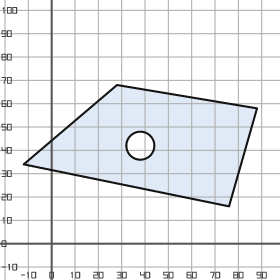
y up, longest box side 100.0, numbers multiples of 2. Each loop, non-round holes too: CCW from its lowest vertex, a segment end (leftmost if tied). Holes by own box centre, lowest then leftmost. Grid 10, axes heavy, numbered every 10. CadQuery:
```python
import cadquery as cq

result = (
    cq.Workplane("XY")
    .moveTo(76.0, 16.0)
    .lineTo(88.0, 58.0)
    .lineTo(28.0, 68.0)
    .lineTo(-12.0, 34.0)
    .close()
    .moveTo(38.0, 42.0)
    .circle(6.0)
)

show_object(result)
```